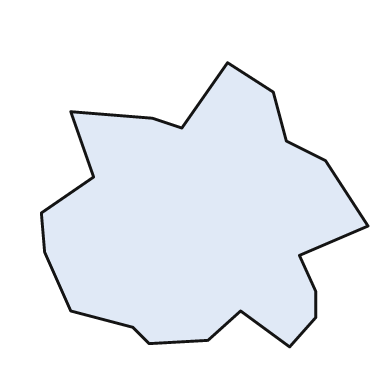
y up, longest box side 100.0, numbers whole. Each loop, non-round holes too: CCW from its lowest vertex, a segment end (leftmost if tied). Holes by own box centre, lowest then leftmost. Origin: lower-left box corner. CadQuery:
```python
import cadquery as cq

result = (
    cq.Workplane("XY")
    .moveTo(76.0, 0.0)
    .lineTo(84.0, 9.0)
    .lineTo(84.0, 17.0)
    .lineTo(79.0, 28.0)
    .lineTo(100.0, 37.0)
    .lineTo(87.0, 57.0)
    .lineTo(75.0, 63.0)
    .lineTo(71.0, 78.0)
    .lineTo(57.0, 87.0)
    .lineTo(43.0, 67.0)
    .lineTo(34.0, 70.0)
    .lineTo(9.0, 72.0)
    .lineTo(16.0, 52.0)
    .lineTo(0.0, 41.0)
    .lineTo(1.0, 29.0)
    .lineTo(9.0, 11.0)
    .lineTo(28.0, 6.0)
    .lineTo(33.0, 1.0)
    .lineTo(51.0, 2.0)
    .lineTo(61.0, 11.0)
    .close()
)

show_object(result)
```